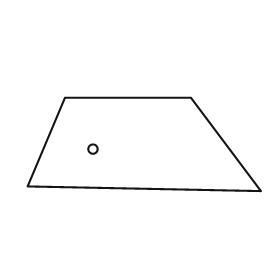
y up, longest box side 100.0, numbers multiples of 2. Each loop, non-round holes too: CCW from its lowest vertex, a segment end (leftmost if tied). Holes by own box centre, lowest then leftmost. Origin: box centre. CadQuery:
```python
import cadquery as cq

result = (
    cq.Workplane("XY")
    .moveTo(50.0, -20.0)
    .lineTo(20.0, 20.0)
    .lineTo(-34.0, 20.0)
    .lineTo(-50.0, -18.0)
    .close()
    .moveTo(-22.0, -2.0)
    .circle(2.0)
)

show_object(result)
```